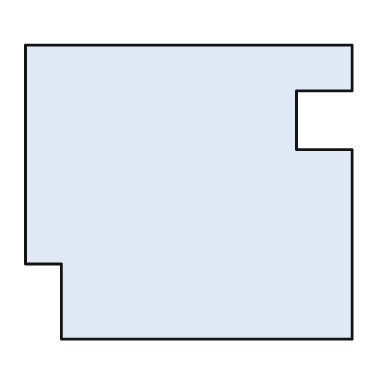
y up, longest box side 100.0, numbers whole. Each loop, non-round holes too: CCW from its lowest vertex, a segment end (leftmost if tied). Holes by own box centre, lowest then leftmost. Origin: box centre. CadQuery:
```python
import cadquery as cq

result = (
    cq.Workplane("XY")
    .moveTo(-39.0, -45.0)
    .lineTo(50.0, -45.0)
    .lineTo(50.0, 13.0)
    .lineTo(33.0, 13.0)
    .lineTo(33.0, 31.0)
    .lineTo(50.0, 31.0)
    .lineTo(50.0, 45.0)
    .lineTo(-50.0, 45.0)
    .lineTo(-50.0, -22.0)
    .lineTo(-39.0, -22.0)
    .close()
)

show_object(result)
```